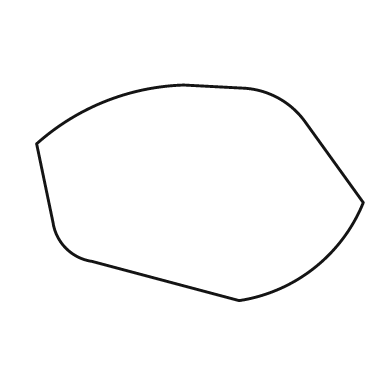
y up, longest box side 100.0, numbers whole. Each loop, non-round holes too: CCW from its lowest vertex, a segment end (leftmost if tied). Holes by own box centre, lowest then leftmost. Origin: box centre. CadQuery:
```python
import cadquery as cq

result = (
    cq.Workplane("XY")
    .moveTo(12.0, -33.0)
    .threePointArc((35.0, -23.0), (50.0, -3.0))
    .lineTo(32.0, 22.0)
    .threePointArc((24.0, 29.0), (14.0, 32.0))
    .lineTo(-5.0, 33.0)
    .threePointArc((-29.0, 28.0), (-50.0, 15.0))
    .lineTo(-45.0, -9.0)
    .threePointArc((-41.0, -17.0), (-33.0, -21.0))
    .close()
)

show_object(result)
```